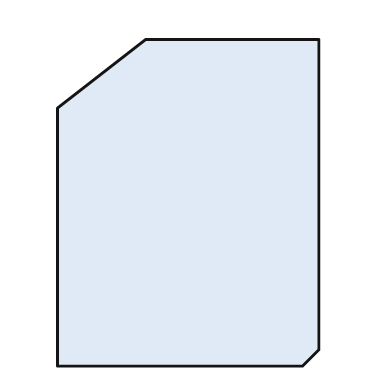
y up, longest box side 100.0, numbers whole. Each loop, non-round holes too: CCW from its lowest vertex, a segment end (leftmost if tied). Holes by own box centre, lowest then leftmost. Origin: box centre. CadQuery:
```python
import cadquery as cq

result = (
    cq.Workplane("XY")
    .moveTo(-40.0, -50.0)
    .lineTo(35.0, -50.0)
    .lineTo(40.0, -45.0)
    .lineTo(40.0, 50.0)
    .lineTo(-13.0, 50.0)
    .lineTo(-40.0, 29.0)
    .close()
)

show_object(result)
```